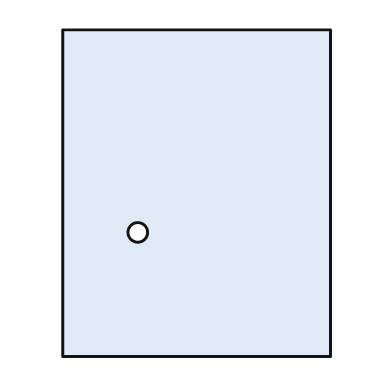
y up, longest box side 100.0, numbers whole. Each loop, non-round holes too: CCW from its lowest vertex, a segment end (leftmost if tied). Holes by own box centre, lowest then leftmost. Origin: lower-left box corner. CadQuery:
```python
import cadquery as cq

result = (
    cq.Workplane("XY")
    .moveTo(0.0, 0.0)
    .lineTo(82.0, 0.0)
    .lineTo(82.0, 100.0)
    .lineTo(0.0, 100.0)
    .close()
    .moveTo(23.0, 38.0)
    .circle(3.0)
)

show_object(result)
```